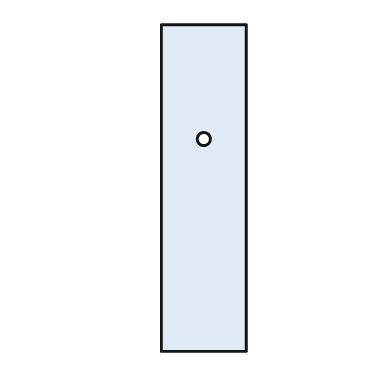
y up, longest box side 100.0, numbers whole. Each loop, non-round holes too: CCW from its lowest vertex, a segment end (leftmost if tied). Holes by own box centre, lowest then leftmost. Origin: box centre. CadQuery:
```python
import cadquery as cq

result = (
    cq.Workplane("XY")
    .moveTo(-13.0, -50.0)
    .lineTo(13.0, -50.0)
    .lineTo(13.0, 50.0)
    .lineTo(-13.0, 50.0)
    .close()
    .moveTo(0.0, 15.0)
    .circle(2.0)
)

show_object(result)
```